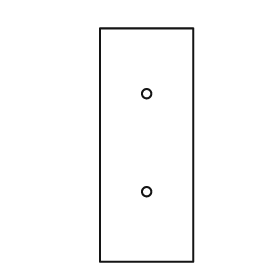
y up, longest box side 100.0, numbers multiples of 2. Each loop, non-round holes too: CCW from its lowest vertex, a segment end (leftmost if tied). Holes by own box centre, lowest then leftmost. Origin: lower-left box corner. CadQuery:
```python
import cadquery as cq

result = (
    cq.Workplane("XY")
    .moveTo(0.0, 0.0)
    .lineTo(40.0, 0.0)
    .lineTo(40.0, 100.0)
    .lineTo(0.0, 100.0)
    .close()
    .moveTo(20.0, 30.0)
    .circle(2.0)
    .moveTo(20.0, 72.0)
    .circle(2.0)
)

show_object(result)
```